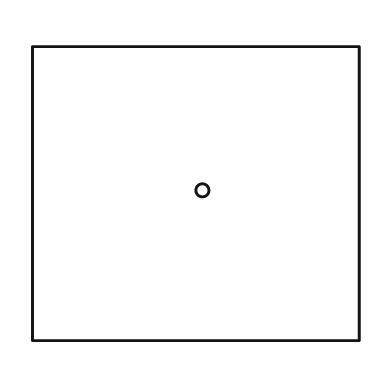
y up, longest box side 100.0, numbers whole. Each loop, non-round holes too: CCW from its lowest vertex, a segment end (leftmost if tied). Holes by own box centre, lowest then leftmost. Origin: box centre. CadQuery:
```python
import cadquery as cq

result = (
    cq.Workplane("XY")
    .moveTo(-50.0, -45.0)
    .lineTo(50.0, -45.0)
    .lineTo(50.0, 45.0)
    .lineTo(-50.0, 45.0)
    .close()
    .moveTo(2.0, 1.0)
    .circle(2.0)
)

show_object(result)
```